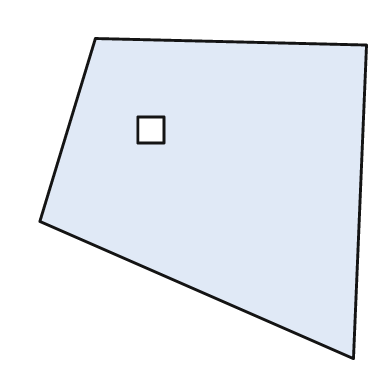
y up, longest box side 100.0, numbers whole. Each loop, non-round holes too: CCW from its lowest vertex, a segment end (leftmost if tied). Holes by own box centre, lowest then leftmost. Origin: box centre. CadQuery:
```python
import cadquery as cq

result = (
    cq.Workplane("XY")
    .moveTo(46.0, -49.0)
    .lineTo(50.0, 47.0)
    .lineTo(-33.0, 49.0)
    .lineTo(-50.0, -7.0)
    .close()
    .moveTo(-20.0, 17.0)
    .lineTo(-12.0, 17.0)
    .lineTo(-12.0, 25.0)
    .lineTo(-20.0, 25.0)
    .close()
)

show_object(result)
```